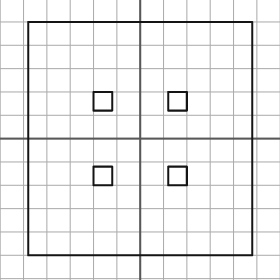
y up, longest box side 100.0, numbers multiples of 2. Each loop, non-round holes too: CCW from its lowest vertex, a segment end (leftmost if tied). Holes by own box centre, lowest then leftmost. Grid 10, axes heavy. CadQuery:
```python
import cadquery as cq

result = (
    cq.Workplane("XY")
    .moveTo(-48.0, -50.0)
    .lineTo(48.0, -50.0)
    .lineTo(48.0, 50.0)
    .lineTo(-48.0, 50.0)
    .close()
    .moveTo(-20.0, -20.0)
    .lineTo(-12.0, -20.0)
    .lineTo(-12.0, -12.0)
    .lineTo(-20.0, -12.0)
    .close()
    .moveTo(12.0, -20.0)
    .lineTo(20.0, -20.0)
    .lineTo(20.0, -12.0)
    .lineTo(12.0, -12.0)
    .close()
    .moveTo(-20.0, 12.0)
    .lineTo(-12.0, 12.0)
    .lineTo(-12.0, 20.0)
    .lineTo(-20.0, 20.0)
    .close()
    .moveTo(12.0, 12.0)
    .lineTo(20.0, 12.0)
    .lineTo(20.0, 20.0)
    .lineTo(12.0, 20.0)
    .close()
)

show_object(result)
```